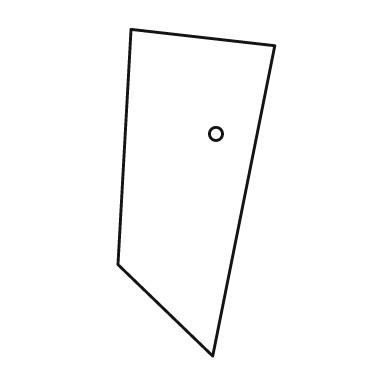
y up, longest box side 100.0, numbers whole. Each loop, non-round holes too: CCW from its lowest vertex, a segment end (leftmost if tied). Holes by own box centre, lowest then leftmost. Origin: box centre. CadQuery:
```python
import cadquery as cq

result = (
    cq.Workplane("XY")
    .moveTo(5.0, -50.0)
    .lineTo(24.0, 45.0)
    .lineTo(-20.0, 50.0)
    .lineTo(-24.0, -22.0)
    .close()
    .moveTo(6.0, 18.0)
    .circle(2.0)
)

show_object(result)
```